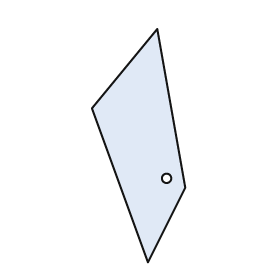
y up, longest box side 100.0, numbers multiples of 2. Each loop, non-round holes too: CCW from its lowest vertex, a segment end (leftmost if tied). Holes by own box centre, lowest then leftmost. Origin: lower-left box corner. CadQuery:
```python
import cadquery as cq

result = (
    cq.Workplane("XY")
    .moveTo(24.0, 0.0)
    .lineTo(40.0, 32.0)
    .lineTo(28.0, 100.0)
    .lineTo(0.0, 66.0)
    .close()
    .moveTo(32.0, 36.0)
    .circle(2.0)
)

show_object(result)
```